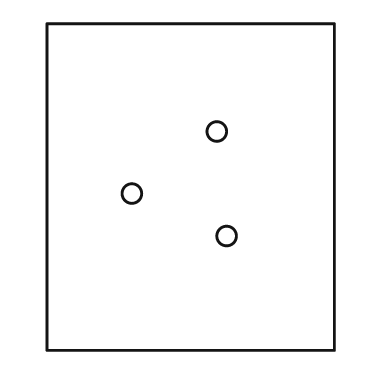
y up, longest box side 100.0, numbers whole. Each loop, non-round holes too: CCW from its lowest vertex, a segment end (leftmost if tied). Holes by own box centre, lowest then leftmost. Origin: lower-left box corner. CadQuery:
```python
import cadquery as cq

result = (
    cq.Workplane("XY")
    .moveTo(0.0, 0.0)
    .lineTo(88.0, 0.0)
    .lineTo(88.0, 100.0)
    .lineTo(0.0, 100.0)
    .close()
    .moveTo(55.0, 35.0)
    .circle(3.0)
    .moveTo(26.0, 48.0)
    .circle(3.0)
    .moveTo(52.0, 67.0)
    .circle(3.0)
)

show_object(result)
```